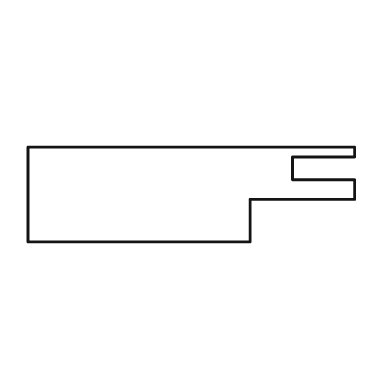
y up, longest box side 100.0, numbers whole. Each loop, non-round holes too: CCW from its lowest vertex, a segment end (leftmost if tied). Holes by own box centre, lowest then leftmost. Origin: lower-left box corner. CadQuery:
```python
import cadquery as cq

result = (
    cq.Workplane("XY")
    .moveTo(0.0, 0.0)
    .lineTo(68.0, 0.0)
    .lineTo(68.0, 13.0)
    .lineTo(100.0, 13.0)
    .lineTo(100.0, 19.0)
    .lineTo(81.0, 19.0)
    .lineTo(81.0, 26.0)
    .lineTo(100.0, 26.0)
    .lineTo(100.0, 29.0)
    .lineTo(0.0, 29.0)
    .close()
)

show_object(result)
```